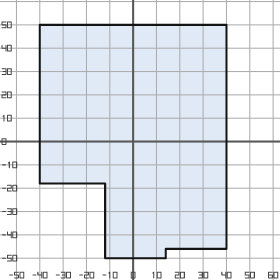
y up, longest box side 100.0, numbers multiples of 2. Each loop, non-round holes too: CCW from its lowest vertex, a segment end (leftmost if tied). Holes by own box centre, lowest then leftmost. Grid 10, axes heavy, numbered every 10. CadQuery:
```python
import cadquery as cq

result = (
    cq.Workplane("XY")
    .moveTo(-12.0, -50.0)
    .lineTo(14.0, -50.0)
    .lineTo(14.0, -46.0)
    .lineTo(40.0, -46.0)
    .lineTo(40.0, 50.0)
    .lineTo(-40.0, 50.0)
    .lineTo(-40.0, -18.0)
    .lineTo(-12.0, -18.0)
    .close()
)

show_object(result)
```